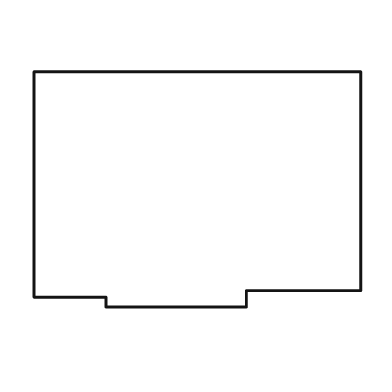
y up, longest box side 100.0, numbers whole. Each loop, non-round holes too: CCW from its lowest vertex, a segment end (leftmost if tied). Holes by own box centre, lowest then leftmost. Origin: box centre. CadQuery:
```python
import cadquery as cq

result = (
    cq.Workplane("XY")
    .moveTo(-28.0, -36.0)
    .lineTo(15.0, -36.0)
    .lineTo(15.0, -31.0)
    .lineTo(50.0, -31.0)
    .lineTo(50.0, 36.0)
    .lineTo(-50.0, 36.0)
    .lineTo(-50.0, -33.0)
    .lineTo(-28.0, -33.0)
    .close()
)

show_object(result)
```